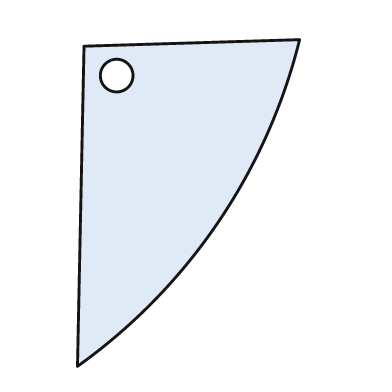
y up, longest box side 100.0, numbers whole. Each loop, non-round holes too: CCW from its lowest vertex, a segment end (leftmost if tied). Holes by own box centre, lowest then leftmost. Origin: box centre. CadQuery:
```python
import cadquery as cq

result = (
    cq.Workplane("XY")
    .moveTo(-34.0, -50.0)
    .threePointArc((9.0, -6.0), (34.0, 50.0))
    .lineTo(-32.0, 48.0)
    .close()
    .moveTo(-22.0, 39.0)
    .circle(5.0)
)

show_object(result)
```